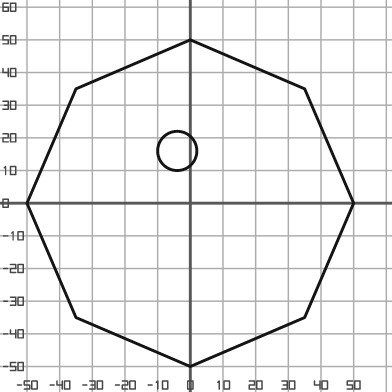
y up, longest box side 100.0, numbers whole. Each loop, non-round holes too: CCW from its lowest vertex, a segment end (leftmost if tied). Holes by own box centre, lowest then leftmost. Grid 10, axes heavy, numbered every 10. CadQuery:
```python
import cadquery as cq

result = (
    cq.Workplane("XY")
    .moveTo(0.0, -50.0)
    .lineTo(35.0, -35.0)
    .lineTo(50.0, 0.0)
    .lineTo(35.0, 35.0)
    .lineTo(0.0, 50.0)
    .lineTo(-35.0, 35.0)
    .lineTo(-50.0, 0.0)
    .lineTo(-35.0, -35.0)
    .close()
    .moveTo(-4.0, 16.0)
    .circle(6.0)
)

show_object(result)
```